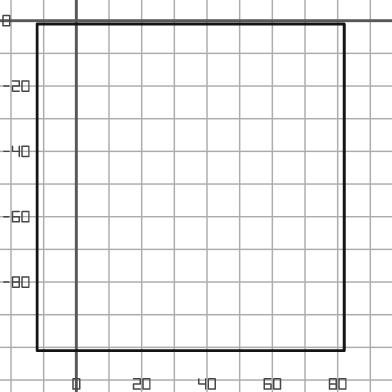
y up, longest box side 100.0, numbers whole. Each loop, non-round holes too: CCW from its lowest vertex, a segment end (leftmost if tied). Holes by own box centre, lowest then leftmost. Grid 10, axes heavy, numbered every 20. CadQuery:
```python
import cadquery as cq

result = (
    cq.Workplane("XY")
    .moveTo(-12.0, -101.0)
    .lineTo(82.0, -101.0)
    .lineTo(82.0, -1.0)
    .lineTo(-12.0, -1.0)
    .close()
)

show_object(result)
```